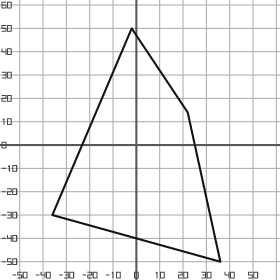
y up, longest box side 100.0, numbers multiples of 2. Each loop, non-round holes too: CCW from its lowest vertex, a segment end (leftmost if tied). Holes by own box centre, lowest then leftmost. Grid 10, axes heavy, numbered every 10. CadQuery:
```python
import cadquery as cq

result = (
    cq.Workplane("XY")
    .moveTo(36.0, -50.0)
    .lineTo(22.0, 14.0)
    .lineTo(-2.0, 50.0)
    .lineTo(-36.0, -30.0)
    .close()
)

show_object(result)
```